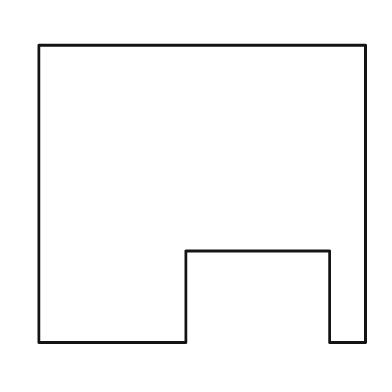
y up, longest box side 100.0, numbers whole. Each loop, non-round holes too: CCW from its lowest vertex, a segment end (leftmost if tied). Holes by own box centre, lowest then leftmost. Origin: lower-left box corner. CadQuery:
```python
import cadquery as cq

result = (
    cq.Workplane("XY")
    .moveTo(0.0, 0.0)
    .lineTo(45.0, 0.0)
    .lineTo(45.0, 28.0)
    .lineTo(89.0, 28.0)
    .lineTo(89.0, 0.0)
    .lineTo(100.0, 0.0)
    .lineTo(100.0, 91.0)
    .lineTo(0.0, 91.0)
    .close()
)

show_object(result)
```